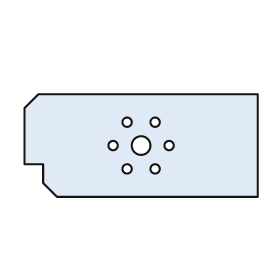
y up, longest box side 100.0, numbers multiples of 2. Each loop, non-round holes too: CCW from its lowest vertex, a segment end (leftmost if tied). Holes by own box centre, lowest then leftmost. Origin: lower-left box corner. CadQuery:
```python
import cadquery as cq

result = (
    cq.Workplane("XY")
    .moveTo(14.0, 0.0)
    .lineTo(100.0, 0.0)
    .lineTo(100.0, 44.0)
    .lineTo(6.0, 44.0)
    .lineTo(0.0, 38.0)
    .lineTo(0.0, 14.0)
    .lineTo(8.0, 14.0)
    .lineTo(8.0, 6.0)
    .close()
    .moveTo(44.0, 12.0)
    .circle(2.0)
    .moveTo(56.0, 12.0)
    .circle(2.0)
    .moveTo(38.0, 22.0)
    .circle(2.0)
    .moveTo(50.0, 22.0)
    .circle(4.0)
    .moveTo(62.0, 22.0)
    .circle(2.0)
    .moveTo(44.0, 32.0)
    .circle(2.0)
    .moveTo(56.0, 32.0)
    .circle(2.0)
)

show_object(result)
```